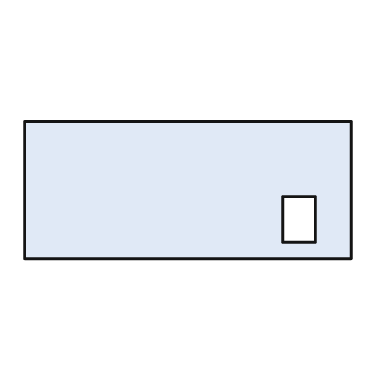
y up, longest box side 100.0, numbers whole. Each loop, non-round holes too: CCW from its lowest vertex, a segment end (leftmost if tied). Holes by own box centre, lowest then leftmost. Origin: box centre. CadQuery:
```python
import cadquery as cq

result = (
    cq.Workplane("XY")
    .moveTo(-50.0, -21.0)
    .lineTo(50.0, -21.0)
    .lineTo(50.0, 21.0)
    .lineTo(-50.0, 21.0)
    .close()
    .moveTo(29.0, -16.0)
    .lineTo(39.0, -16.0)
    .lineTo(39.0, -2.0)
    .lineTo(29.0, -2.0)
    .close()
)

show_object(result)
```